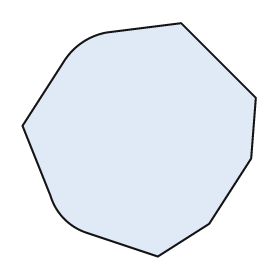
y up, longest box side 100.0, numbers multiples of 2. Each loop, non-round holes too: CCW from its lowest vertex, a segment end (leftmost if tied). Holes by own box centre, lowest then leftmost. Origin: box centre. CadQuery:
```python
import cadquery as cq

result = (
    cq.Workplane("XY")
    .moveTo(8.0, -50.0)
    .lineTo(30.0, -36.0)
    .lineTo(48.0, -8.0)
    .lineTo(50.0, 18.0)
    .lineTo(18.0, 50.0)
    .lineTo(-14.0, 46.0)
    .threePointArc((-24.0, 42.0), (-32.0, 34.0))
    .lineTo(-50.0, 6.0)
    .lineTo(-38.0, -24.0)
    .threePointArc((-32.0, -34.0), (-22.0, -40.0))
    .close()
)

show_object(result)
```